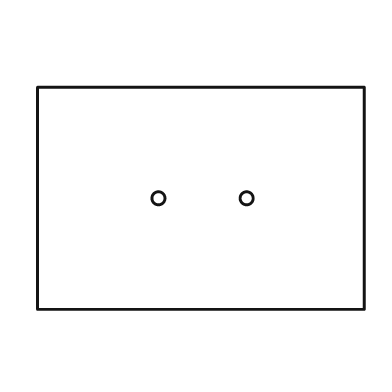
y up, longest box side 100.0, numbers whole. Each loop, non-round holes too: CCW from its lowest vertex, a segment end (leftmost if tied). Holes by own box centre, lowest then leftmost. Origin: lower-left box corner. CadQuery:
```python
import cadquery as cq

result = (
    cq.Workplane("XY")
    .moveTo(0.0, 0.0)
    .lineTo(100.0, 0.0)
    .lineTo(100.0, 68.0)
    .lineTo(0.0, 68.0)
    .close()
    .moveTo(37.0, 34.0)
    .circle(2.0)
    .moveTo(64.0, 34.0)
    .circle(2.0)
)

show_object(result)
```